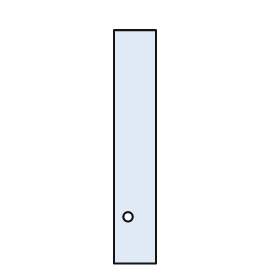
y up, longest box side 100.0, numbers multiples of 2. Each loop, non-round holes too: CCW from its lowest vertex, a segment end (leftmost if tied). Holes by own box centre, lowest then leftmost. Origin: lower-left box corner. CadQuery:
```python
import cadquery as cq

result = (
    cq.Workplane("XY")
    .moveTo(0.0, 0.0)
    .lineTo(18.0, 0.0)
    .lineTo(18.0, 100.0)
    .lineTo(0.0, 100.0)
    .close()
    .moveTo(6.0, 20.0)
    .circle(2.0)
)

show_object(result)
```